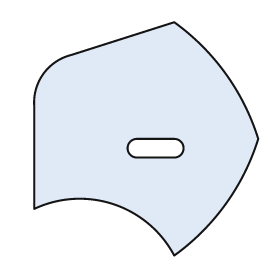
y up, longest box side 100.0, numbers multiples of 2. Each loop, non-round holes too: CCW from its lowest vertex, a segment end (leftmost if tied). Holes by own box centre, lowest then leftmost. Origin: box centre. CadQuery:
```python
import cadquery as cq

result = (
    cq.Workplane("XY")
    .moveTo(12.0, -50.0)
    .threePointArc((34.0, -28.0), (48.0, 0.0))
    .threePointArc((34.0, 28.0), (12.0, 50.0))
    .lineTo(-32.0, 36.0)
    .threePointArc((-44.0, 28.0), (-48.0, 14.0))
    .lineTo(-48.0, -30.0)
    .threePointArc((-14.0, -28.0), (12.0, -50.0))
    .close()
    .moveTo(-4.0, -8.0)
    .lineTo(12.0, -8.0)
    .threePointArc((16.0, -4.0), (12.0, 0.0))
    .lineTo(-4.0, 0.0)
    .threePointArc((-8.0, -4.0), (-4.0, -8.0))
    .close()
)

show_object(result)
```